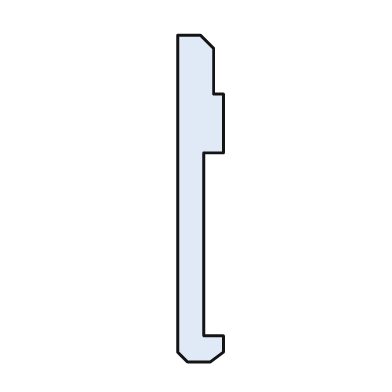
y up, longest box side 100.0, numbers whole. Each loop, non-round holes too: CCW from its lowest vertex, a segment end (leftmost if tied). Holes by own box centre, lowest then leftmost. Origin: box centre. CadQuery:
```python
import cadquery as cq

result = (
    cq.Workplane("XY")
    .moveTo(-4.0, -50.0)
    .lineTo(3.0, -50.0)
    .lineTo(7.0, -47.0)
    .lineTo(7.0, -42.0)
    .lineTo(1.0, -42.0)
    .lineTo(1.0, 14.0)
    .lineTo(7.0, 14.0)
    .lineTo(7.0, 32.0)
    .lineTo(4.0, 32.0)
    .lineTo(4.0, 46.0)
    .lineTo(0.0, 50.0)
    .lineTo(-7.0, 50.0)
    .lineTo(-7.0, -47.0)
    .close()
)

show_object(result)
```